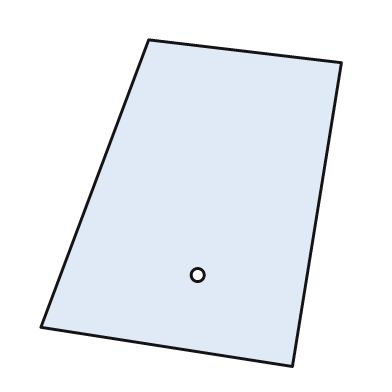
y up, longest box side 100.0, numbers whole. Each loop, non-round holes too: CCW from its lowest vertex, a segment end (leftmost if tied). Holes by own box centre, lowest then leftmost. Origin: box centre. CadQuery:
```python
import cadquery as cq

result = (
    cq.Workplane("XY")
    .moveTo(31.0, -50.0)
    .lineTo(46.0, 43.0)
    .lineTo(-13.0, 50.0)
    .lineTo(-46.0, -38.0)
    .close()
    .moveTo(2.0, -22.0)
    .circle(2.0)
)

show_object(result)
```